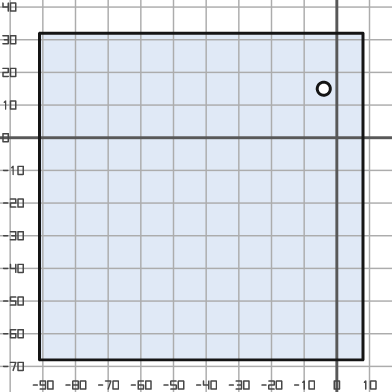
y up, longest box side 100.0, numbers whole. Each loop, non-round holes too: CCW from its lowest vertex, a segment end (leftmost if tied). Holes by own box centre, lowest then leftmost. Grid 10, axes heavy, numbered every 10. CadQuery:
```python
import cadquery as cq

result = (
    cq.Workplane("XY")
    .moveTo(-91.0, -68.0)
    .lineTo(8.0, -68.0)
    .lineTo(8.0, 32.0)
    .lineTo(-91.0, 32.0)
    .close()
    .moveTo(-4.0, 15.0)
    .circle(2.0)
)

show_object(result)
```